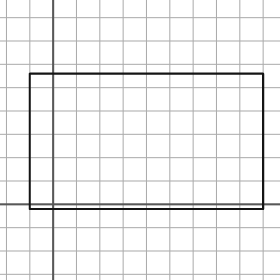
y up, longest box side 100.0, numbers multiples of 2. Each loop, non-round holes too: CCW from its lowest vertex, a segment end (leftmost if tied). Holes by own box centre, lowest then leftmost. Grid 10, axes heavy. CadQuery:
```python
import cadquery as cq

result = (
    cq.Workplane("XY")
    .moveTo(-10.0, -2.0)
    .lineTo(90.0, -2.0)
    .lineTo(90.0, 56.0)
    .lineTo(-10.0, 56.0)
    .close()
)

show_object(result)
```